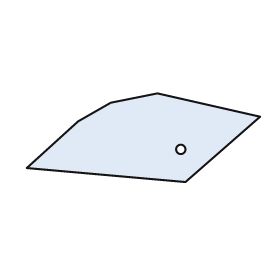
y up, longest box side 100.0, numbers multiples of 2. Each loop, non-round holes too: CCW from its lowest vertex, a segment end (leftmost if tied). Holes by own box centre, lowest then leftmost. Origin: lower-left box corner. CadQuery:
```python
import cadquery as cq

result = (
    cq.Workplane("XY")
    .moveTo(68.0, 0.0)
    .lineTo(100.0, 28.0)
    .lineTo(56.0, 38.0)
    .lineTo(36.0, 34.0)
    .lineTo(22.0, 26.0)
    .lineTo(0.0, 6.0)
    .close()
    .moveTo(66.0, 14.0)
    .circle(2.0)
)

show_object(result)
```